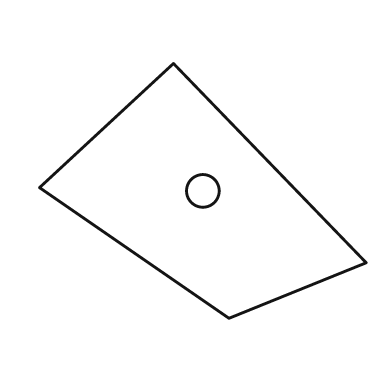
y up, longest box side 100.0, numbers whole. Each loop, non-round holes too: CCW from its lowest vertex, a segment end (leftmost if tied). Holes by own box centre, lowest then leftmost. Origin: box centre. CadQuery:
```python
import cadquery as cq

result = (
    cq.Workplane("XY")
    .moveTo(8.0, -39.0)
    .lineTo(50.0, -22.0)
    .lineTo(-9.0, 39.0)
    .lineTo(-50.0, 1.0)
    .close()
    .moveTo(0.0, 0.0)
    .circle(5.0)
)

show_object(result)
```